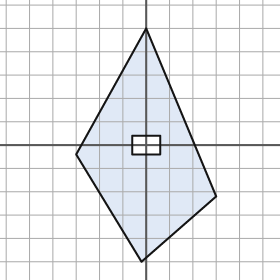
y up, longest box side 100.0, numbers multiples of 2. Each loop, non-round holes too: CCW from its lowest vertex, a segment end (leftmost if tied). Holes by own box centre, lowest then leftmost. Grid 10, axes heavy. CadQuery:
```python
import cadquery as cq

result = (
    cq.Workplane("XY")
    .moveTo(-2.0, -50.0)
    .lineTo(30.0, -22.0)
    .lineTo(0.0, 50.0)
    .lineTo(-30.0, -4.0)
    .close()
    .moveTo(-6.0, -4.0)
    .lineTo(6.0, -4.0)
    .lineTo(6.0, 4.0)
    .lineTo(-6.0, 4.0)
    .close()
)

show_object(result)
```